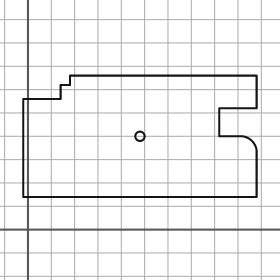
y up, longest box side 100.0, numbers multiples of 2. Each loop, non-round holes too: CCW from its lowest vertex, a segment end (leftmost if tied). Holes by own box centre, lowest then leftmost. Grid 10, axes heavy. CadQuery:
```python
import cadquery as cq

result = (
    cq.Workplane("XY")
    .moveTo(-2.0, 14.0)
    .lineTo(98.0, 14.0)
    .lineTo(98.0, 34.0)
    .threePointArc((96.0, 38.0), (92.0, 40.0))
    .lineTo(82.0, 40.0)
    .lineTo(82.0, 52.0)
    .lineTo(98.0, 52.0)
    .lineTo(98.0, 66.0)
    .lineTo(18.0, 66.0)
    .lineTo(18.0, 62.0)
    .lineTo(14.0, 62.0)
    .lineTo(14.0, 56.0)
    .lineTo(-2.0, 56.0)
    .close()
    .moveTo(48.0, 40.0)
    .circle(2.0)
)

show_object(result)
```